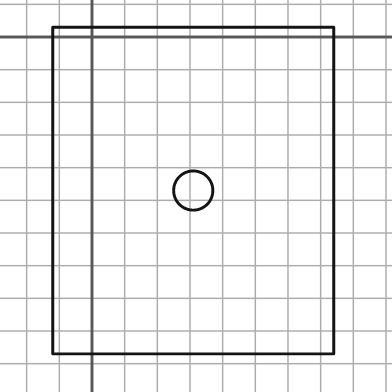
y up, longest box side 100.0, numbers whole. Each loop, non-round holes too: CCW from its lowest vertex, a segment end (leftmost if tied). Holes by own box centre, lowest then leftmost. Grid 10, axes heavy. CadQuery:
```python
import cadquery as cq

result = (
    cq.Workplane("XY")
    .moveTo(-12.0, -97.0)
    .lineTo(74.0, -97.0)
    .lineTo(74.0, 3.0)
    .lineTo(-12.0, 3.0)
    .close()
    .moveTo(31.0, -47.0)
    .circle(6.0)
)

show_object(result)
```